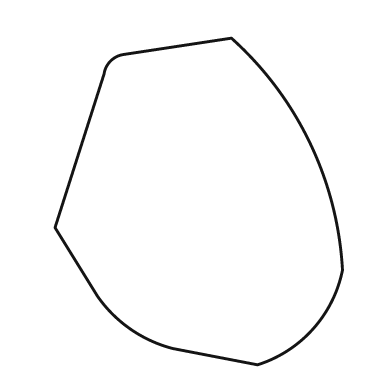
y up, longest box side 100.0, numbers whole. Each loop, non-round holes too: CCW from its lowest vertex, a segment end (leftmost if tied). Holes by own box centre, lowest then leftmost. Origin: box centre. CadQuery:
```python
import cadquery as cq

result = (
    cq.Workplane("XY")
    .moveTo(18.0, -50.0)
    .threePointArc((35.0, -39.0), (44.0, -21.0))
    .threePointArc((34.0, 18.0), (10.0, 50.0))
    .lineTo(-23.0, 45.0)
    .threePointArc((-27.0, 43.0), (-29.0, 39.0))
    .lineTo(-44.0, -8.0)
    .lineTo(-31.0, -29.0)
    .threePointArc((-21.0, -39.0), (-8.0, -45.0))
    .close()
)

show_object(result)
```